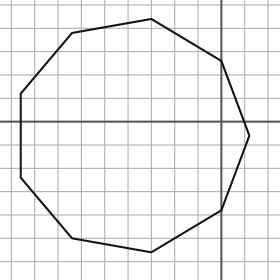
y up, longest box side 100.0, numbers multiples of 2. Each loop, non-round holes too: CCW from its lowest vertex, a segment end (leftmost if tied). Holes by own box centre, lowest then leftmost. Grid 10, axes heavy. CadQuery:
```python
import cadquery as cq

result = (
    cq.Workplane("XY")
    .moveTo(-30.0, -56.0)
    .lineTo(0.0, -38.0)
    .lineTo(12.0, -6.0)
    .lineTo(0.0, 26.0)
    .lineTo(-30.0, 44.0)
    .lineTo(-64.0, 38.0)
    .lineTo(-86.0, 12.0)
    .lineTo(-86.0, -24.0)
    .lineTo(-64.0, -50.0)
    .close()
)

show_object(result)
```